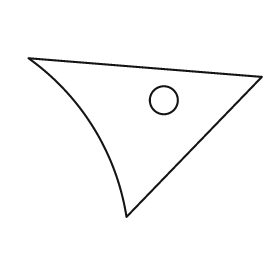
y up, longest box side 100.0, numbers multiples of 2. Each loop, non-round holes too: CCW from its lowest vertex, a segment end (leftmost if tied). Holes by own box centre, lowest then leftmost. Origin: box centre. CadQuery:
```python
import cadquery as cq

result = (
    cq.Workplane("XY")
    .moveTo(-8.0, -34.0)
    .lineTo(50.0, 26.0)
    .lineTo(-50.0, 34.0)
    .threePointArc((-22.0, 4.0), (-8.0, -34.0))
    .close()
    .moveTo(8.0, 16.0)
    .circle(6.0)
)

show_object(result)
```